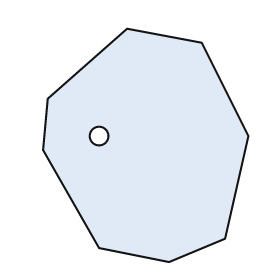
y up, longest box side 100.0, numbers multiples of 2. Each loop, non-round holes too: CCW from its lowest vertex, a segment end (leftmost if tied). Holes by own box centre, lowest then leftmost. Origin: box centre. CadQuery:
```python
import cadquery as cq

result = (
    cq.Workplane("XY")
    .moveTo(10.0, -50.0)
    .lineTo(34.0, -40.0)
    .lineTo(44.0, 4.0)
    .lineTo(24.0, 44.0)
    .lineTo(-8.0, 50.0)
    .lineTo(-42.0, 20.0)
    .lineTo(-44.0, -2.0)
    .lineTo(-20.0, -44.0)
    .close()
    .moveTo(-20.0, 4.0)
    .circle(4.0)
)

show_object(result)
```